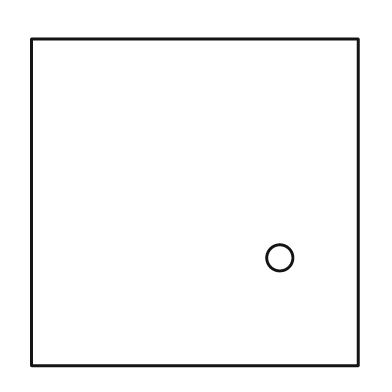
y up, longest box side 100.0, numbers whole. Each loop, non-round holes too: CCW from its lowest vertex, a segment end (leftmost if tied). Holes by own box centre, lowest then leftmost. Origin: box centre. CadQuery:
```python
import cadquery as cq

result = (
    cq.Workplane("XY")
    .moveTo(-50.0, -50.0)
    .lineTo(50.0, -50.0)
    .lineTo(50.0, 50.0)
    .lineTo(-50.0, 50.0)
    .close()
    .moveTo(26.0, -17.0)
    .circle(4.0)
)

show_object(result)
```